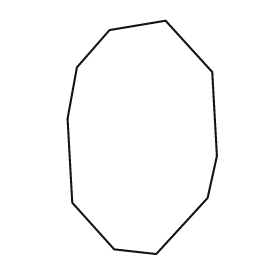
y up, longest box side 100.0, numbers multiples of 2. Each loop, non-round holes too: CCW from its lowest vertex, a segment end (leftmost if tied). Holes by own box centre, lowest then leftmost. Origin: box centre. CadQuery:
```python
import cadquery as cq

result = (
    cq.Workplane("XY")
    .moveTo(6.0, -50.0)
    .lineTo(28.0, -26.0)
    .lineTo(32.0, -8.0)
    .lineTo(30.0, 28.0)
    .lineTo(10.0, 50.0)
    .lineTo(-14.0, 46.0)
    .lineTo(-28.0, 30.0)
    .lineTo(-32.0, 8.0)
    .lineTo(-30.0, -28.0)
    .lineTo(-12.0, -48.0)
    .close()
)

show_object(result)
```